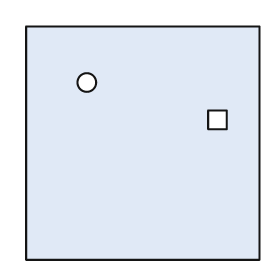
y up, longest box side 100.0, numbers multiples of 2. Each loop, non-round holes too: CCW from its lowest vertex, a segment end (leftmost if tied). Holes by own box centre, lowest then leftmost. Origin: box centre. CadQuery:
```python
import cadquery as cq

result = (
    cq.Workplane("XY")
    .moveTo(-50.0, -50.0)
    .lineTo(50.0, -50.0)
    .lineTo(50.0, 50.0)
    .lineTo(-50.0, 50.0)
    .close()
    .moveTo(28.0, 6.0)
    .lineTo(36.0, 6.0)
    .lineTo(36.0, 14.0)
    .lineTo(28.0, 14.0)
    .close()
    .moveTo(-24.0, 26.0)
    .circle(4.0)
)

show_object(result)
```